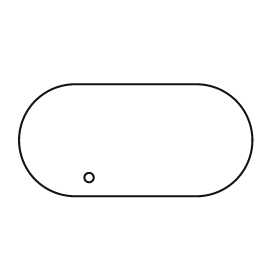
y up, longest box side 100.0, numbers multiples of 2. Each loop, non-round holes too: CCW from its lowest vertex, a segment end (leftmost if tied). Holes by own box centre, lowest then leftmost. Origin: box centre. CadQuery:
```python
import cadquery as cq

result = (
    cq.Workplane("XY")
    .moveTo(-26.0, -24.0)
    .lineTo(26.0, -24.0)
    .threePointArc((50.0, 0.0), (26.0, 24.0))
    .lineTo(-26.0, 24.0)
    .threePointArc((-50.0, 0.0), (-26.0, -24.0))
    .close()
    .moveTo(-20.0, -16.0)
    .circle(2.0)
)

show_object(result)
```